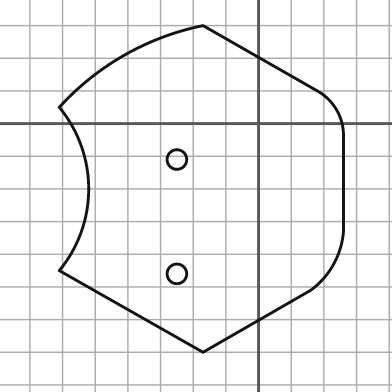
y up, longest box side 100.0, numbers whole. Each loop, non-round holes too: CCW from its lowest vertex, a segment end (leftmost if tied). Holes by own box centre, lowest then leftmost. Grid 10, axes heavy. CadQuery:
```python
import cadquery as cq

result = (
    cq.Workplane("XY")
    .moveTo(-17.0, -70.0)
    .lineTo(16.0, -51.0)
    .threePointArc((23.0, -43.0), (26.0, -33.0))
    .lineTo(26.0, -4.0)
    .threePointArc((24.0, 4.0), (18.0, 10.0))
    .lineTo(-17.0, 30.0)
    .threePointArc((-41.0, 21.0), (-61.0, 5.0))
    .threePointArc((-52.0, -20.0), (-61.0, -45.0))
    .close()
    .moveTo(-25.0, -46.0)
    .circle(3.0)
    .moveTo(-25.0, -11.0)
    .circle(3.0)
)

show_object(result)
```